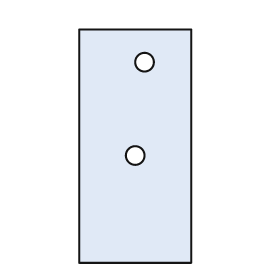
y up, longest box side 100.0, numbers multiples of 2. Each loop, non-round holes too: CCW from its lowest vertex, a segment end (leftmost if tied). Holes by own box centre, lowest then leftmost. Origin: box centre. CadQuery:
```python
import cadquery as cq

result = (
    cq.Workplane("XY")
    .moveTo(-24.0, -50.0)
    .lineTo(24.0, -50.0)
    .lineTo(24.0, 50.0)
    .lineTo(-24.0, 50.0)
    .close()
    .moveTo(0.0, -4.0)
    .circle(4.0)
    .moveTo(4.0, 36.0)
    .circle(4.0)
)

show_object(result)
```